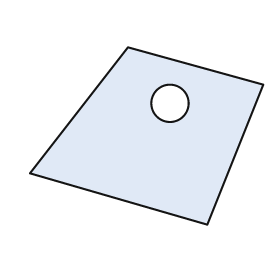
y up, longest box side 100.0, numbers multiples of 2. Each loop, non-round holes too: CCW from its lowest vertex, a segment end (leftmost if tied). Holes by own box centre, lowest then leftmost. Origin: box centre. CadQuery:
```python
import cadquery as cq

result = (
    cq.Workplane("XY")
    .moveTo(26.0, -38.0)
    .lineTo(50.0, 22.0)
    .lineTo(-8.0, 38.0)
    .lineTo(-50.0, -16.0)
    .close()
    .moveTo(10.0, 14.0)
    .circle(8.0)
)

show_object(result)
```